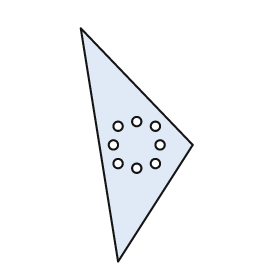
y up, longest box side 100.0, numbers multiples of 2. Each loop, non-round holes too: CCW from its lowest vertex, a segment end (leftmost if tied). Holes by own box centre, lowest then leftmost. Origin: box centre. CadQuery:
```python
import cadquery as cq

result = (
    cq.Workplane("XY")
    .moveTo(-8.0, -50.0)
    .lineTo(24.0, 0.0)
    .lineTo(-24.0, 50.0)
    .close()
    .moveTo(0.0, -10.0)
    .circle(2.0)
    .moveTo(-8.0, -8.0)
    .circle(2.0)
    .moveTo(8.0, -8.0)
    .circle(2.0)
    .moveTo(-10.0, 0.0)
    .circle(2.0)
    .moveTo(10.0, 0.0)
    .circle(2.0)
    .moveTo(-8.0, 8.0)
    .circle(2.0)
    .moveTo(8.0, 8.0)
    .circle(2.0)
    .moveTo(0.0, 10.0)
    .circle(2.0)
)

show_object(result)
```